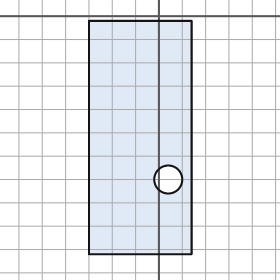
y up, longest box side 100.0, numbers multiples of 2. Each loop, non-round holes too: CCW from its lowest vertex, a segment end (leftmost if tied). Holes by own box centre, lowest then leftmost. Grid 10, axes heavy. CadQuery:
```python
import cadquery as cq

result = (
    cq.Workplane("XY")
    .moveTo(-30.0, -102.0)
    .lineTo(14.0, -102.0)
    .lineTo(14.0, -2.0)
    .lineTo(-30.0, -2.0)
    .close()
    .moveTo(4.0, -70.0)
    .circle(6.0)
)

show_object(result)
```